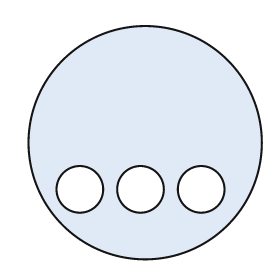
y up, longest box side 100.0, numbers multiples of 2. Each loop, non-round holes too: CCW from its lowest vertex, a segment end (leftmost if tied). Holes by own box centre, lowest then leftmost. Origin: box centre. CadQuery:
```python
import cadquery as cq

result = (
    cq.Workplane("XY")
    .moveTo(0.0, 0.0)
    .circle(50.0)
    .moveTo(-28.0, -20.0)
    .circle(10.0)
    .moveTo(-2.0, -20.0)
    .circle(10.0)
    .moveTo(24.0, -20.0)
    .circle(10.0)
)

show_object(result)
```